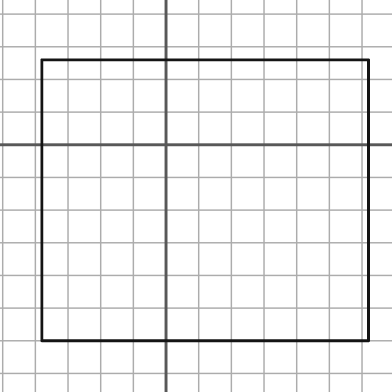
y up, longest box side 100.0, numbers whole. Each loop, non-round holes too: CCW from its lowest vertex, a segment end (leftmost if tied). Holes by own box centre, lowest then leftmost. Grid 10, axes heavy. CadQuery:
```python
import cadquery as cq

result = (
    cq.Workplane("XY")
    .moveTo(-38.0, -60.0)
    .lineTo(62.0, -60.0)
    .lineTo(62.0, 26.0)
    .lineTo(-38.0, 26.0)
    .close()
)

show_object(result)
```